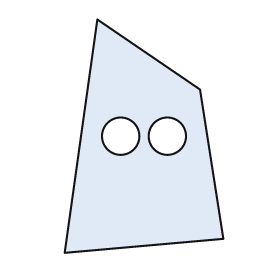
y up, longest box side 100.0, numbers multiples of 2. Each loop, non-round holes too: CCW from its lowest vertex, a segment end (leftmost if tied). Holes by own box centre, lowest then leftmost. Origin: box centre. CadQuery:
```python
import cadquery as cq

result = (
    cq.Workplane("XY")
    .moveTo(-34.0, -50.0)
    .lineTo(34.0, -44.0)
    .lineTo(24.0, 20.0)
    .lineTo(-20.0, 50.0)
    .close()
    .moveTo(-10.0, 0.0)
    .circle(8.0)
    .moveTo(10.0, 0.0)
    .circle(8.0)
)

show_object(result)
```